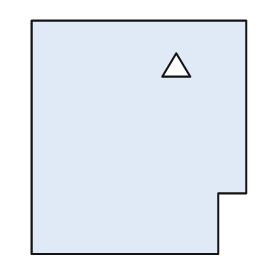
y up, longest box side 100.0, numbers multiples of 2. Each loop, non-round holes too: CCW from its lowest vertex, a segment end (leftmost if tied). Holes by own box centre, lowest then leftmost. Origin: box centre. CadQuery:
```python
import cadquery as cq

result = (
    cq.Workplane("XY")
    .moveTo(-46.0, -50.0)
    .lineTo(34.0, -50.0)
    .lineTo(34.0, -24.0)
    .lineTo(46.0, -24.0)
    .lineTo(46.0, 50.0)
    .lineTo(-46.0, 50.0)
    .close()
    .moveTo(10.0, 26.0)
    .lineTo(22.0, 26.0)
    .lineTo(16.0, 36.0)
    .close()
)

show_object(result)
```